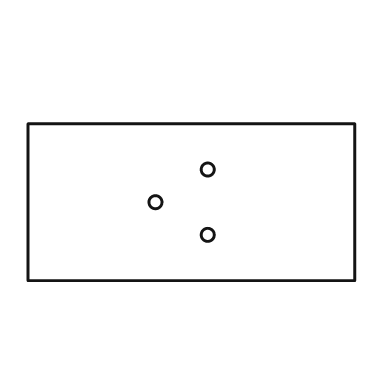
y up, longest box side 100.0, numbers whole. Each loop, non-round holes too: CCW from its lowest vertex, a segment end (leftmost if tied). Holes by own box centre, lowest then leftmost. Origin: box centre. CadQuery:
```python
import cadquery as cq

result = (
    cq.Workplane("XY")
    .moveTo(-50.0, -24.0)
    .lineTo(50.0, -24.0)
    .lineTo(50.0, 24.0)
    .lineTo(-50.0, 24.0)
    .close()
    .moveTo(5.0, -10.0)
    .circle(2.0)
    .moveTo(-11.0, 0.0)
    .circle(2.0)
    .moveTo(5.0, 10.0)
    .circle(2.0)
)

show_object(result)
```